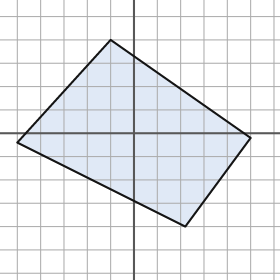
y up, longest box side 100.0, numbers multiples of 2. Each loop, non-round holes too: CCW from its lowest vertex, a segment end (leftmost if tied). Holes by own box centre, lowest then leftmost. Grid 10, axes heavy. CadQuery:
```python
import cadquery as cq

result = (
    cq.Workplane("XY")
    .moveTo(22.0, -40.0)
    .lineTo(50.0, -2.0)
    .lineTo(-10.0, 40.0)
    .lineTo(-50.0, -4.0)
    .close()
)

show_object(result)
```